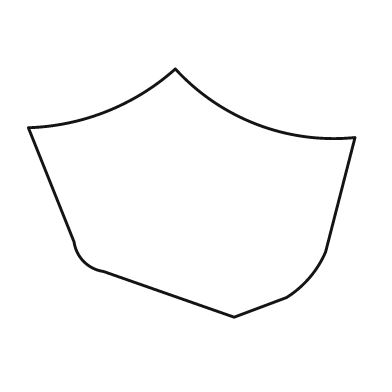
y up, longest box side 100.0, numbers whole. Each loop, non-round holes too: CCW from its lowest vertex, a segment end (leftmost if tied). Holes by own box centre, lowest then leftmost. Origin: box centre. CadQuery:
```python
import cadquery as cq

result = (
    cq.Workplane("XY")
    .moveTo(13.0, -38.0)
    .lineTo(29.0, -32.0)
    .threePointArc((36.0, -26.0), (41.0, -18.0))
    .lineTo(50.0, 17.0)
    .threePointArc((20.0, 21.0), (-5.0, 38.0))
    .threePointArc((-26.0, 25.0), (-50.0, 20.0))
    .lineTo(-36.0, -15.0)
    .threePointArc((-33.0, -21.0), (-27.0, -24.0))
    .close()
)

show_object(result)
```